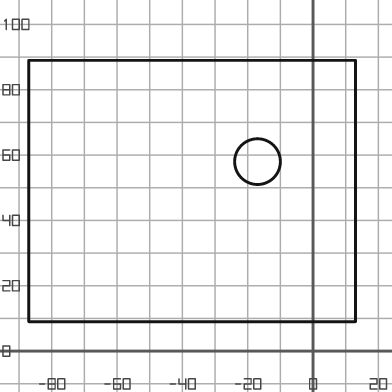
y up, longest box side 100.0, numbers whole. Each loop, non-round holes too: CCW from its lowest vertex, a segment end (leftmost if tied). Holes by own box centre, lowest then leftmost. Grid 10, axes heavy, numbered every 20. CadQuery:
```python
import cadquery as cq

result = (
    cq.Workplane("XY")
    .moveTo(-87.0, 9.0)
    .lineTo(13.0, 9.0)
    .lineTo(13.0, 89.0)
    .lineTo(-87.0, 89.0)
    .close()
    .moveTo(-17.0, 58.0)
    .circle(7.0)
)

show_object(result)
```